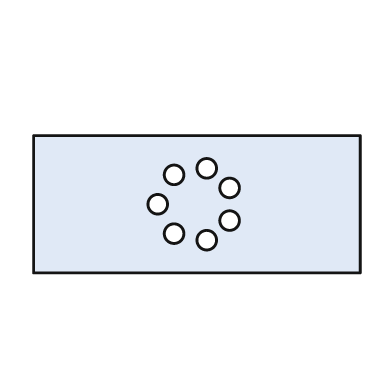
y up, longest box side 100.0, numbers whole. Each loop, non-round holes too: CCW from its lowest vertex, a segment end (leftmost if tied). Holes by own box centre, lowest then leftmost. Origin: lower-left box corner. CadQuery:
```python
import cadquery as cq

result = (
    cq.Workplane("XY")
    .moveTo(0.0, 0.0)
    .lineTo(100.0, 0.0)
    .lineTo(100.0, 42.0)
    .lineTo(0.0, 42.0)
    .close()
    .moveTo(53.0, 10.0)
    .circle(3.0)
    .moveTo(43.0, 12.0)
    .circle(3.0)
    .moveTo(60.0, 16.0)
    .circle(3.0)
    .moveTo(38.0, 21.0)
    .circle(3.0)
    .moveTo(60.0, 26.0)
    .circle(3.0)
    .moveTo(43.0, 30.0)
    .circle(3.0)
    .moveTo(53.0, 32.0)
    .circle(3.0)
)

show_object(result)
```